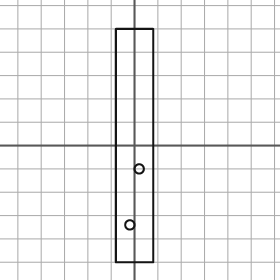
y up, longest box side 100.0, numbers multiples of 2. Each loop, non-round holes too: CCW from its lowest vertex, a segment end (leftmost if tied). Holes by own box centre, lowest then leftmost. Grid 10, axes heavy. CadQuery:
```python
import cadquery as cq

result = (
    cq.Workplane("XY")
    .moveTo(-8.0, -50.0)
    .lineTo(8.0, -50.0)
    .lineTo(8.0, 50.0)
    .lineTo(-8.0, 50.0)
    .close()
    .moveTo(-2.0, -34.0)
    .circle(2.0)
    .moveTo(2.0, -10.0)
    .circle(2.0)
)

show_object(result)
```